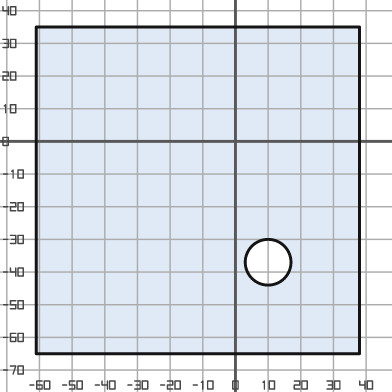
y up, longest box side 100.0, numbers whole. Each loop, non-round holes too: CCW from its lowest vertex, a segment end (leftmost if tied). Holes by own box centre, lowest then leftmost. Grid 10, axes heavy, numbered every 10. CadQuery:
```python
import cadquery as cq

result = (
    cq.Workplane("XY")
    .moveTo(-61.0, -65.0)
    .lineTo(38.0, -65.0)
    .lineTo(38.0, 35.0)
    .lineTo(-61.0, 35.0)
    .close()
    .moveTo(10.0, -37.0)
    .circle(7.0)
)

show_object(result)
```